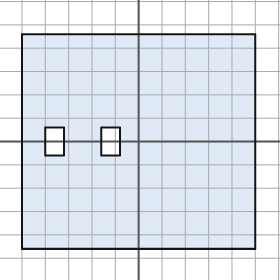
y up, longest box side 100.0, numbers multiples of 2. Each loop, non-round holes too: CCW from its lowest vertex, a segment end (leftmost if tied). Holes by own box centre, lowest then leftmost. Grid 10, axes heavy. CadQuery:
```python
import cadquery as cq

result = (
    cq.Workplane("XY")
    .moveTo(-50.0, -46.0)
    .lineTo(50.0, -46.0)
    .lineTo(50.0, 46.0)
    .lineTo(-50.0, 46.0)
    .close()
    .moveTo(-40.0, -6.0)
    .lineTo(-32.0, -6.0)
    .lineTo(-32.0, 6.0)
    .lineTo(-40.0, 6.0)
    .close()
    .moveTo(-16.0, -6.0)
    .lineTo(-8.0, -6.0)
    .lineTo(-8.0, 6.0)
    .lineTo(-16.0, 6.0)
    .close()
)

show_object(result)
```